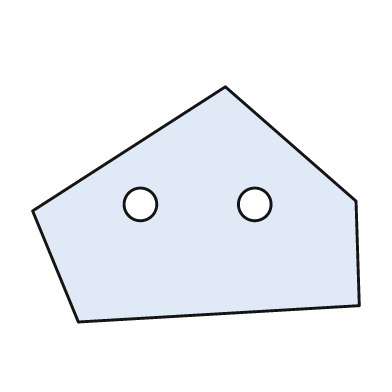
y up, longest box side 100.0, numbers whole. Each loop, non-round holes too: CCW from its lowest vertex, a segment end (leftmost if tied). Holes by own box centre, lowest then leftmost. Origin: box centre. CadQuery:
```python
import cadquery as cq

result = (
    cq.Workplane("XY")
    .moveTo(-36.0, -36.0)
    .lineTo(50.0, -31.0)
    .lineTo(49.0, 1.0)
    .lineTo(9.0, 36.0)
    .lineTo(-50.0, -2.0)
    .close()
    .moveTo(-17.0, 0.0)
    .circle(5.0)
    .moveTo(18.0, 0.0)
    .circle(5.0)
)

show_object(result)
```